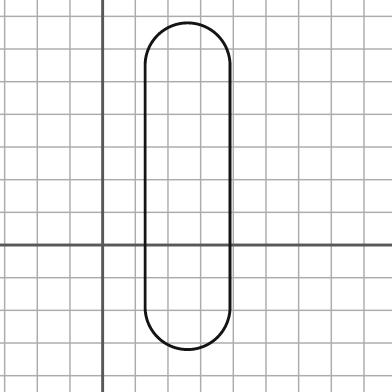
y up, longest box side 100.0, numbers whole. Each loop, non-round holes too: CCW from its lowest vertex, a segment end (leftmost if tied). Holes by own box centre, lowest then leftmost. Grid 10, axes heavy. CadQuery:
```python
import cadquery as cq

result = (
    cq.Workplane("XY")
    .moveTo(13.0, -19.0)
    .threePointArc((26.0, -32.0), (39.0, -19.0))
    .lineTo(39.0, 55.0)
    .threePointArc((26.0, 68.0), (13.0, 55.0))
    .close()
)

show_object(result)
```